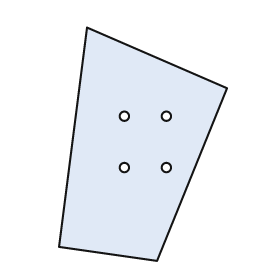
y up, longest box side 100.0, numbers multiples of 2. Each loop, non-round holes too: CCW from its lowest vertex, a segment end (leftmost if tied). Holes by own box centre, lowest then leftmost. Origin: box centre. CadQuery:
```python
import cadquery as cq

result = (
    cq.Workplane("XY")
    .moveTo(6.0, -50.0)
    .lineTo(36.0, 24.0)
    .lineTo(-24.0, 50.0)
    .lineTo(-36.0, -44.0)
    .close()
    .moveTo(-8.0, -10.0)
    .circle(2.0)
    .moveTo(10.0, -10.0)
    .circle(2.0)
    .moveTo(-8.0, 12.0)
    .circle(2.0)
    .moveTo(10.0, 12.0)
    .circle(2.0)
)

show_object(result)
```